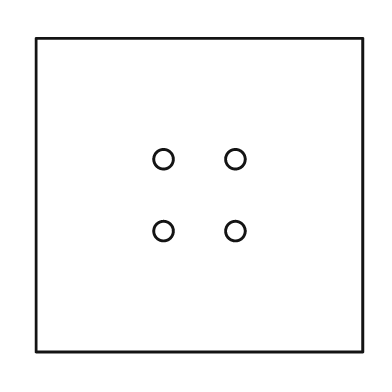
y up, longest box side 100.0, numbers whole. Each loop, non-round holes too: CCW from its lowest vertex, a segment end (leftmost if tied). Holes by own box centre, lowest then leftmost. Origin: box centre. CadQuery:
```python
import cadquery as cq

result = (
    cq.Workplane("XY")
    .moveTo(-50.0, -48.0)
    .lineTo(50.0, -48.0)
    .lineTo(50.0, 48.0)
    .lineTo(-50.0, 48.0)
    .close()
    .moveTo(-11.0, -11.0)
    .circle(3.0)
    .moveTo(11.0, -11.0)
    .circle(3.0)
    .moveTo(-11.0, 11.0)
    .circle(3.0)
    .moveTo(11.0, 11.0)
    .circle(3.0)
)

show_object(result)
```